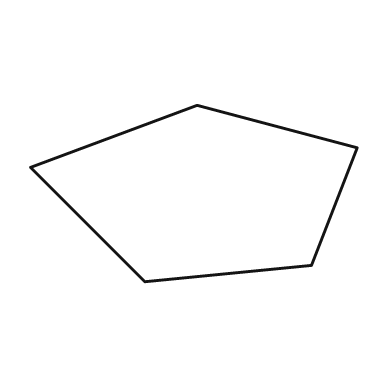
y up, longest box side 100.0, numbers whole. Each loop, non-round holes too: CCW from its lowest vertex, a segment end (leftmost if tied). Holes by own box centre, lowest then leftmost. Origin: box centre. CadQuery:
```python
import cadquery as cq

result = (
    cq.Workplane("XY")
    .moveTo(-15.0, -27.0)
    .lineTo(36.0, -22.0)
    .lineTo(50.0, 14.0)
    .lineTo(1.0, 27.0)
    .lineTo(-50.0, 8.0)
    .close()
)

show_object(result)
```